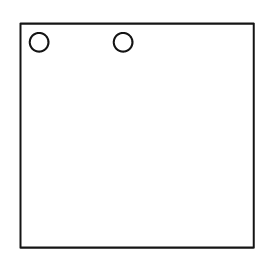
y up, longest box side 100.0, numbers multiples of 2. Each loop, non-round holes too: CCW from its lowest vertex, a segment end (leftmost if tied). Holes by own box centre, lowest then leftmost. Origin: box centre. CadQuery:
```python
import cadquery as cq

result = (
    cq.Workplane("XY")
    .moveTo(-50.0, -48.0)
    .lineTo(50.0, -48.0)
    .lineTo(50.0, 48.0)
    .lineTo(-50.0, 48.0)
    .close()
    .moveTo(-42.0, 40.0)
    .circle(4.0)
    .moveTo(-6.0, 40.0)
    .circle(4.0)
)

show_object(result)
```